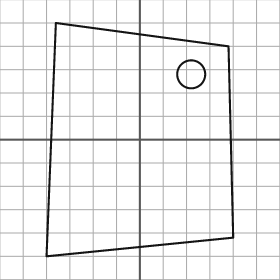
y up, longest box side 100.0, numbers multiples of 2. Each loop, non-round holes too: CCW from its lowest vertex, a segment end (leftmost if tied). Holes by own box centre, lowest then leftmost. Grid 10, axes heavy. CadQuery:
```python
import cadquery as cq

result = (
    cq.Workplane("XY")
    .moveTo(-40.0, -50.0)
    .lineTo(40.0, -42.0)
    .lineTo(38.0, 40.0)
    .lineTo(-36.0, 50.0)
    .close()
    .moveTo(22.0, 28.0)
    .circle(6.0)
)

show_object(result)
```